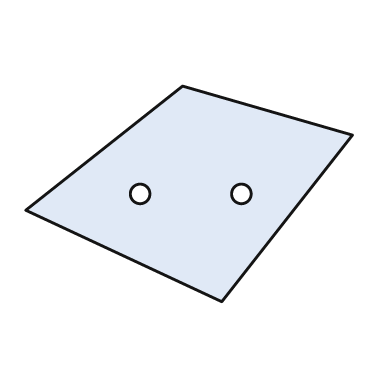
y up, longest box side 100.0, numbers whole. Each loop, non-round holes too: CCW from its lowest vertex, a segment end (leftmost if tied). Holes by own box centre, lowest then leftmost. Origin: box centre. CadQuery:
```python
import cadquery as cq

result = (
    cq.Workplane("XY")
    .moveTo(10.0, -33.0)
    .lineTo(50.0, 18.0)
    .lineTo(-2.0, 33.0)
    .lineTo(-50.0, -5.0)
    .close()
    .moveTo(-15.0, 0.0)
    .circle(3.0)
    .moveTo(16.0, 0.0)
    .circle(3.0)
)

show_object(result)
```